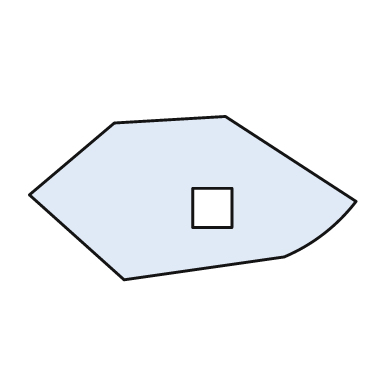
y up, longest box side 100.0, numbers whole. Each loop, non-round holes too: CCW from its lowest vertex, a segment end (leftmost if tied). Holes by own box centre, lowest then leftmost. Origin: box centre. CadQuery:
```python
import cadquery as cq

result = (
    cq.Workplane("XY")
    .moveTo(-21.0, -25.0)
    .lineTo(28.0, -18.0)
    .threePointArc((40.0, -11.0), (50.0, -1.0))
    .lineTo(10.0, 25.0)
    .lineTo(-24.0, 23.0)
    .lineTo(-50.0, 1.0)
    .close()
    .moveTo(0.0, -9.0)
    .lineTo(12.0, -9.0)
    .lineTo(12.0, 3.0)
    .lineTo(0.0, 3.0)
    .close()
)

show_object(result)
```